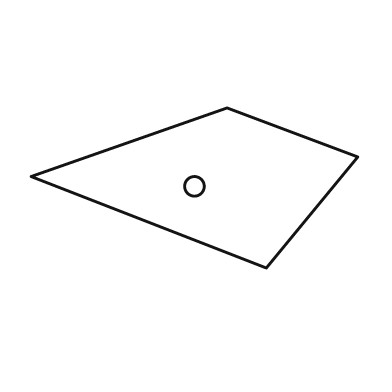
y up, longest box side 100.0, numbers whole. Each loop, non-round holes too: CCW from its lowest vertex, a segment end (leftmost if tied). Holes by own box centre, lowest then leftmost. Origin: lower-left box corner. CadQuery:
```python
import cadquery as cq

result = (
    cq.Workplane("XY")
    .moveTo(72.0, 0.0)
    .lineTo(100.0, 34.0)
    .lineTo(60.0, 49.0)
    .lineTo(0.0, 28.0)
    .close()
    .moveTo(50.0, 25.0)
    .circle(3.0)
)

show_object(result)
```